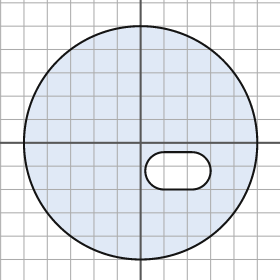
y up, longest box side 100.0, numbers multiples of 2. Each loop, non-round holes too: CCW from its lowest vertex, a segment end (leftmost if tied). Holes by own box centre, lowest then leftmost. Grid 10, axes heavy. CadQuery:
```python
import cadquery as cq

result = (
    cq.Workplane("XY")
    .moveTo(0.0, 0.0)
    .circle(50.0)
    .moveTo(10.0, -20.0)
    .lineTo(22.0, -20.0)
    .threePointArc((30.0, -12.0), (22.0, -4.0))
    .lineTo(10.0, -4.0)
    .threePointArc((2.0, -12.0), (10.0, -20.0))
    .close()
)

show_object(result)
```